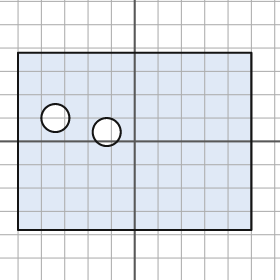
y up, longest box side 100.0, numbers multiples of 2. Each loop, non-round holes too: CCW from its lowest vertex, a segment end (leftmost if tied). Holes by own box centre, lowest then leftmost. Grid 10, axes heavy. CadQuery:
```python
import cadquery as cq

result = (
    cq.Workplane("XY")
    .moveTo(-50.0, -38.0)
    .lineTo(50.0, -38.0)
    .lineTo(50.0, 38.0)
    .lineTo(-50.0, 38.0)
    .close()
    .moveTo(-12.0, 4.0)
    .circle(6.0)
    .moveTo(-34.0, 10.0)
    .circle(6.0)
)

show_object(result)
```